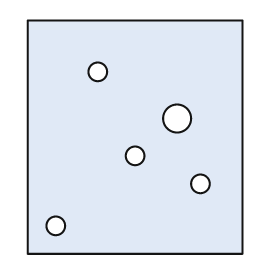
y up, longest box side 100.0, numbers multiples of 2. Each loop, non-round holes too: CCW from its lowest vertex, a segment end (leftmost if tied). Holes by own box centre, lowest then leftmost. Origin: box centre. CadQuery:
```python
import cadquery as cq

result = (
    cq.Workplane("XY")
    .moveTo(-46.0, -50.0)
    .lineTo(46.0, -50.0)
    .lineTo(46.0, 50.0)
    .lineTo(-46.0, 50.0)
    .close()
    .moveTo(-34.0, -38.0)
    .circle(4.0)
    .moveTo(28.0, -20.0)
    .circle(4.0)
    .moveTo(0.0, -8.0)
    .circle(4.0)
    .moveTo(18.0, 8.0)
    .circle(6.0)
    .moveTo(-16.0, 28.0)
    .circle(4.0)
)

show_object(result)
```